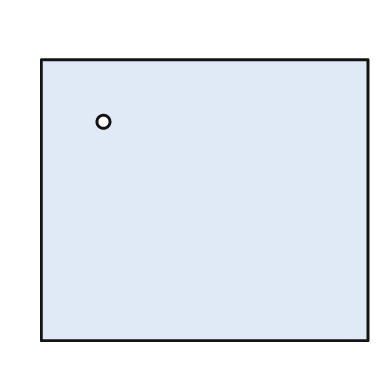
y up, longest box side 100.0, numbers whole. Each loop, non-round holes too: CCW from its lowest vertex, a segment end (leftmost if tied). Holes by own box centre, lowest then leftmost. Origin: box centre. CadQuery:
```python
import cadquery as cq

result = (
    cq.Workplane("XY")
    .moveTo(-50.0, -43.0)
    .lineTo(50.0, -43.0)
    .lineTo(50.0, 43.0)
    .lineTo(-50.0, 43.0)
    .close()
    .moveTo(-31.0, 24.0)
    .circle(2.0)
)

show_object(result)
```